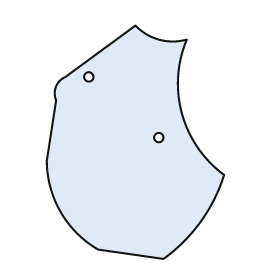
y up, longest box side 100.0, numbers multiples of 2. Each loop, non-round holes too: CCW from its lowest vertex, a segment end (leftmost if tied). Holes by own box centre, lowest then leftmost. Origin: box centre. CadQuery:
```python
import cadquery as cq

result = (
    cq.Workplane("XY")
    .moveTo(12.0, -50.0)
    .threePointArc((28.0, -34.0), (38.0, -14.0))
    .threePointArc((20.0, 12.0), (22.0, 44.0))
    .threePointArc((10.0, 44.0), (0.0, 50.0))
    .lineTo(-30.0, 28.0)
    .threePointArc((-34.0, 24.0), (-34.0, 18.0))
    .lineTo(-38.0, -8.0)
    .threePointArc((-32.0, -30.0), (-16.0, -46.0))
    .close()
    .moveTo(10.0, 2.0)
    .circle(2.0)
    .moveTo(-20.0, 28.0)
    .circle(2.0)
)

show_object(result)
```